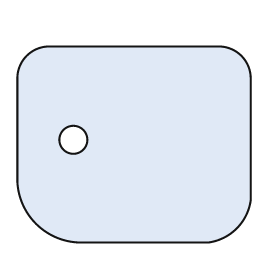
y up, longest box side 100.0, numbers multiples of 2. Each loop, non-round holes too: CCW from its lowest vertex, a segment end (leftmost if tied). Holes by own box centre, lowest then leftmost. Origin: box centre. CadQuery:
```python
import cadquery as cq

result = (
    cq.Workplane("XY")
    .moveTo(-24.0, -42.0)
    .lineTo(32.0, -42.0)
    .threePointArc((44.0, -36.0), (50.0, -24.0))
    .lineTo(50.0, 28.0)
    .threePointArc((46.0, 38.0), (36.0, 42.0))
    .lineTo(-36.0, 42.0)
    .threePointArc((-46.0, 38.0), (-50.0, 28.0))
    .lineTo(-50.0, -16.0)
    .threePointArc((-42.0, -34.0), (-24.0, -42.0))
    .close()
    .moveTo(-26.0, 2.0)
    .circle(6.0)
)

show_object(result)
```